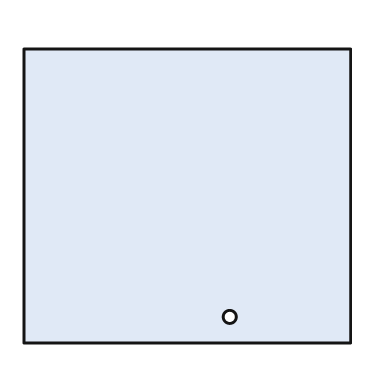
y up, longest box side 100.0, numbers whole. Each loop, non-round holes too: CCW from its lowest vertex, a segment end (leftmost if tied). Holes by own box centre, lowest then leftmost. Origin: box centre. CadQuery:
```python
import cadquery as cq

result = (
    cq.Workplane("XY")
    .moveTo(-50.0, -45.0)
    .lineTo(50.0, -45.0)
    .lineTo(50.0, 45.0)
    .lineTo(-50.0, 45.0)
    .close()
    .moveTo(13.0, -37.0)
    .circle(2.0)
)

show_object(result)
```